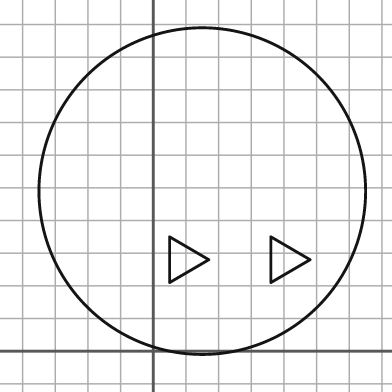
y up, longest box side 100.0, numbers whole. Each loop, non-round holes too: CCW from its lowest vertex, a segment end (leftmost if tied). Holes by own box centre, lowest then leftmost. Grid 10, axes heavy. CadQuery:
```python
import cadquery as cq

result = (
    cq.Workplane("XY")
    .moveTo(15.0, 49.0)
    .circle(50.0)
    .moveTo(5.0, 21.0)
    .lineTo(17.0, 28.0)
    .lineTo(5.0, 35.0)
    .close()
    .moveTo(36.0, 21.0)
    .lineTo(48.0, 28.0)
    .lineTo(36.0, 35.0)
    .close()
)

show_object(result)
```